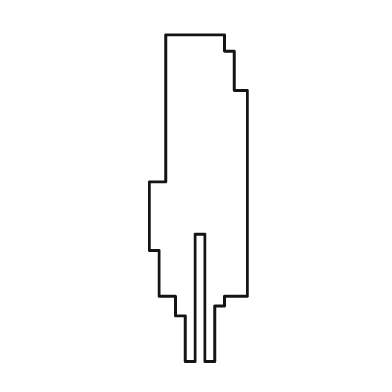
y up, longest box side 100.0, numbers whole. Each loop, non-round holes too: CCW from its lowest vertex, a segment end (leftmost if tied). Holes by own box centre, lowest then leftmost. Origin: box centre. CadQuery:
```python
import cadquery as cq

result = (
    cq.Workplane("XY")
    .moveTo(-4.0, -50.0)
    .lineTo(-1.0, -50.0)
    .lineTo(-1.0, -11.0)
    .lineTo(2.0, -11.0)
    .lineTo(2.0, -50.0)
    .lineTo(5.0, -50.0)
    .lineTo(5.0, -33.0)
    .lineTo(8.0, -33.0)
    .lineTo(8.0, -30.0)
    .lineTo(15.0, -30.0)
    .lineTo(15.0, 33.0)
    .lineTo(11.0, 33.0)
    .lineTo(11.0, 45.0)
    .lineTo(8.0, 45.0)
    .lineTo(8.0, 50.0)
    .lineTo(-10.0, 50.0)
    .lineTo(-10.0, 5.0)
    .lineTo(-15.0, 5.0)
    .lineTo(-15.0, -16.0)
    .lineTo(-12.0, -16.0)
    .lineTo(-12.0, -30.0)
    .lineTo(-7.0, -30.0)
    .lineTo(-7.0, -36.0)
    .lineTo(-4.0, -36.0)
    .close()
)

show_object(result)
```